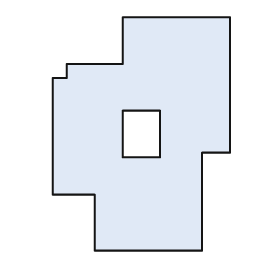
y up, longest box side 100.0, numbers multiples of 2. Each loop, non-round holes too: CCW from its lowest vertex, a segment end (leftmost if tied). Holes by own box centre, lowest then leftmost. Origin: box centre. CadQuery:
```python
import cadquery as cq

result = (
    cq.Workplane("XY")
    .moveTo(-20.0, -50.0)
    .lineTo(26.0, -50.0)
    .lineTo(26.0, -8.0)
    .lineTo(38.0, -8.0)
    .lineTo(38.0, 50.0)
    .lineTo(-8.0, 50.0)
    .lineTo(-8.0, 30.0)
    .lineTo(-32.0, 30.0)
    .lineTo(-32.0, 24.0)
    .lineTo(-38.0, 24.0)
    .lineTo(-38.0, -26.0)
    .lineTo(-20.0, -26.0)
    .close()
    .moveTo(-8.0, -10.0)
    .lineTo(8.0, -10.0)
    .lineTo(8.0, 10.0)
    .lineTo(-8.0, 10.0)
    .close()
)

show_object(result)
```